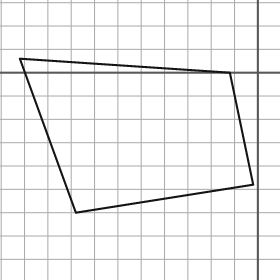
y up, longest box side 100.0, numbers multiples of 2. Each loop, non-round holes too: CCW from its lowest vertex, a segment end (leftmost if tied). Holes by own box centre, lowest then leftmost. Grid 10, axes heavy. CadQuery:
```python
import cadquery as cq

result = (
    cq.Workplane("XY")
    .moveTo(-78.0, -60.0)
    .lineTo(-2.0, -48.0)
    .lineTo(-12.0, 0.0)
    .lineTo(-102.0, 6.0)
    .close()
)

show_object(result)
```